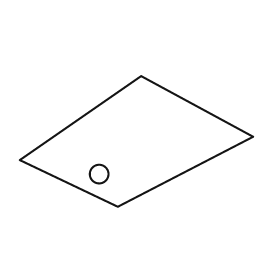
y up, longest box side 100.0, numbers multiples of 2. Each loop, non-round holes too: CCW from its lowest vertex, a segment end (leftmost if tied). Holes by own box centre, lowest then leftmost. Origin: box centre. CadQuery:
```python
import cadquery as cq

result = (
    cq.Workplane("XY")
    .moveTo(-8.0, -28.0)
    .lineTo(50.0, 2.0)
    .lineTo(2.0, 28.0)
    .lineTo(-50.0, -8.0)
    .close()
    .moveTo(-16.0, -14.0)
    .circle(4.0)
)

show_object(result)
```